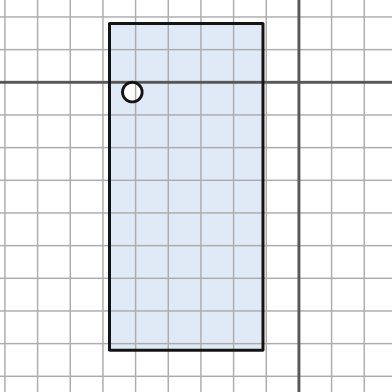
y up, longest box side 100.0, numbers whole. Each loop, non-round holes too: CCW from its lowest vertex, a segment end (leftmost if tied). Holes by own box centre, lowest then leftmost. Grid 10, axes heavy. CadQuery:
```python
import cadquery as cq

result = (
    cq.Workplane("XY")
    .moveTo(-58.0, -82.0)
    .lineTo(-11.0, -82.0)
    .lineTo(-11.0, 18.0)
    .lineTo(-58.0, 18.0)
    .close()
    .moveTo(-51.0, -3.0)
    .circle(3.0)
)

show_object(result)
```